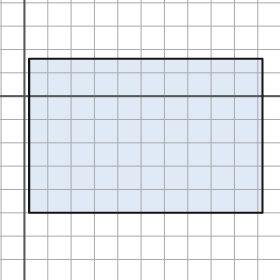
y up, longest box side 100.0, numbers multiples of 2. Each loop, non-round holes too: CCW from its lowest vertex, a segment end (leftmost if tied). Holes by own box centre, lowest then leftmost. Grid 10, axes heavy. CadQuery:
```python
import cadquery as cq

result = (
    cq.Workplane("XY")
    .moveTo(2.0, -50.0)
    .lineTo(102.0, -50.0)
    .lineTo(102.0, 16.0)
    .lineTo(2.0, 16.0)
    .close()
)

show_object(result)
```